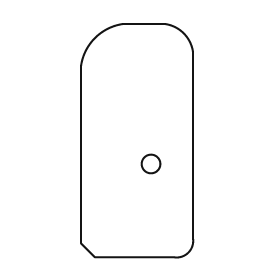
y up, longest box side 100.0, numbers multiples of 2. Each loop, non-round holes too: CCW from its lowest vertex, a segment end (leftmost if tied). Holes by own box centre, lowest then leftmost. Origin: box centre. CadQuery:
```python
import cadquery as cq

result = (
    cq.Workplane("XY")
    .moveTo(-18.0, -50.0)
    .lineTo(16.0, -50.0)
    .threePointArc((22.0, -48.0), (24.0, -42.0))
    .lineTo(24.0, 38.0)
    .threePointArc((20.0, 46.0), (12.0, 50.0))
    .lineTo(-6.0, 50.0)
    .threePointArc((-18.0, 44.0), (-24.0, 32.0))
    .lineTo(-24.0, -44.0)
    .close()
    .moveTo(6.0, -10.0)
    .circle(4.0)
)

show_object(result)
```